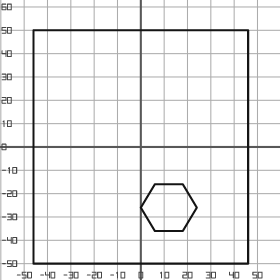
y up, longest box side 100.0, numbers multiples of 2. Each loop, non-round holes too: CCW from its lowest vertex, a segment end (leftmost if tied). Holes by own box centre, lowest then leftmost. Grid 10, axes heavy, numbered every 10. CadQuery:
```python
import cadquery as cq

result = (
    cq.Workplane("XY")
    .moveTo(-46.0, -50.0)
    .lineTo(46.0, -50.0)
    .lineTo(46.0, 50.0)
    .lineTo(-46.0, 50.0)
    .close()
    .moveTo(6.0, -36.0)
    .lineTo(18.0, -36.0)
    .lineTo(24.0, -26.0)
    .lineTo(18.0, -16.0)
    .lineTo(6.0, -16.0)
    .lineTo(0.0, -26.0)
    .close()
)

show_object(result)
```